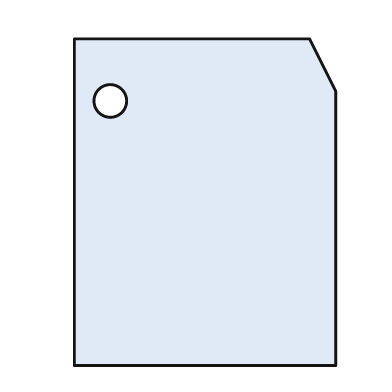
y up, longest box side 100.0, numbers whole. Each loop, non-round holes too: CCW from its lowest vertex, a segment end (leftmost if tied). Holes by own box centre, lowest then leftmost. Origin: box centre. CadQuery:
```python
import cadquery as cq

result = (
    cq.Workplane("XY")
    .moveTo(-40.0, -50.0)
    .lineTo(40.0, -50.0)
    .lineTo(40.0, 34.0)
    .lineTo(32.0, 50.0)
    .lineTo(-40.0, 50.0)
    .close()
    .moveTo(-29.0, 31.0)
    .circle(5.0)
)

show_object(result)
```